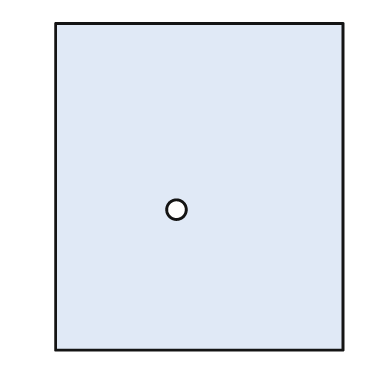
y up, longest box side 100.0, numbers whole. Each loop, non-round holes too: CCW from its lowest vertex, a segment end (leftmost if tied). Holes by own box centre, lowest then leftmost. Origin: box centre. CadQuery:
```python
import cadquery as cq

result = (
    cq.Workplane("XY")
    .moveTo(-44.0, -50.0)
    .lineTo(44.0, -50.0)
    .lineTo(44.0, 50.0)
    .lineTo(-44.0, 50.0)
    .close()
    .moveTo(-7.0, -7.0)
    .circle(3.0)
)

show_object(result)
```